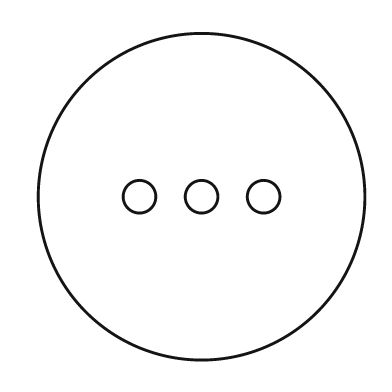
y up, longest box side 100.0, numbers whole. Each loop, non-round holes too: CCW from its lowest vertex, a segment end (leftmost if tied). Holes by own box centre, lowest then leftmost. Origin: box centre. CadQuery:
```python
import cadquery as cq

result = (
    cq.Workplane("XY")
    .moveTo(0.0, 0.0)
    .circle(50.0)
    .moveTo(-19.0, 0.0)
    .circle(5.0)
    .moveTo(0.0, 0.0)
    .circle(5.0)
    .moveTo(19.0, 0.0)
    .circle(5.0)
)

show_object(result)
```